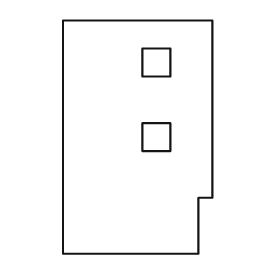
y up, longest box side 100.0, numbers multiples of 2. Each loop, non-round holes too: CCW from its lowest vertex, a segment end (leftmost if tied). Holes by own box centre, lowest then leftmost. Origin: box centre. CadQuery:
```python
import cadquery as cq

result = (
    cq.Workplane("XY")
    .moveTo(-32.0, -50.0)
    .lineTo(26.0, -50.0)
    .lineTo(26.0, -26.0)
    .lineTo(32.0, -26.0)
    .lineTo(32.0, 50.0)
    .lineTo(-32.0, 50.0)
    .close()
    .moveTo(2.0, -6.0)
    .lineTo(14.0, -6.0)
    .lineTo(14.0, 6.0)
    .lineTo(2.0, 6.0)
    .close()
    .moveTo(2.0, 26.0)
    .lineTo(14.0, 26.0)
    .lineTo(14.0, 38.0)
    .lineTo(2.0, 38.0)
    .close()
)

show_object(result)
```